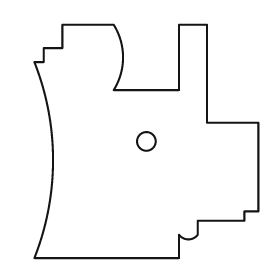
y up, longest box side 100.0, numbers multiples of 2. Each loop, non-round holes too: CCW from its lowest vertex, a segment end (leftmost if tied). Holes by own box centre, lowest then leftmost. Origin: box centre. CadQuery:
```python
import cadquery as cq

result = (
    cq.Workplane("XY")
    .moveTo(-48.0, -50.0)
    .lineTo(14.0, -50.0)
    .lineTo(14.0, -40.0)
    .threePointArc((18.0, -42.0), (22.0, -40.0))
    .lineTo(22.0, -34.0)
    .lineTo(42.0, -34.0)
    .lineTo(42.0, -30.0)
    .lineTo(48.0, -30.0)
    .lineTo(48.0, 8.0)
    .lineTo(26.0, 8.0)
    .lineTo(26.0, 50.0)
    .lineTo(14.0, 50.0)
    .lineTo(14.0, 22.0)
    .lineTo(-14.0, 22.0)
    .threePointArc((-10.0, 36.0), (-14.0, 50.0))
    .lineTo(-36.0, 50.0)
    .lineTo(-36.0, 40.0)
    .lineTo(-44.0, 40.0)
    .lineTo(-44.0, 34.0)
    .lineTo(-48.0, 34.0)
    .threePointArc((-40.0, -8.0), (-48.0, -50.0))
    .close()
    .moveTo(0.0, 0.0)
    .circle(4.0)
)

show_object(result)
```